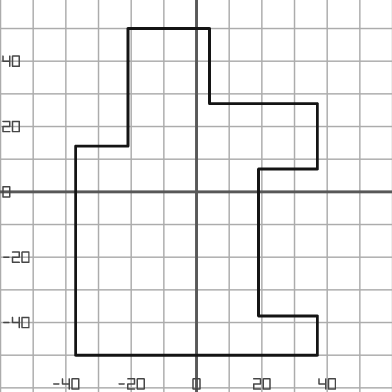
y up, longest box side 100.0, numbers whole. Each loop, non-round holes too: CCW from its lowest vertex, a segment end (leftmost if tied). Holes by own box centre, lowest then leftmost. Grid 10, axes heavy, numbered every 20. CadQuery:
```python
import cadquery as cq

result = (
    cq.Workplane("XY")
    .moveTo(-37.0, -50.0)
    .lineTo(37.0, -50.0)
    .lineTo(37.0, -38.0)
    .lineTo(19.0, -38.0)
    .lineTo(19.0, 7.0)
    .lineTo(37.0, 7.0)
    .lineTo(37.0, 27.0)
    .lineTo(4.0, 27.0)
    .lineTo(4.0, 50.0)
    .lineTo(-21.0, 50.0)
    .lineTo(-21.0, 14.0)
    .lineTo(-37.0, 14.0)
    .close()
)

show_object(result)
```